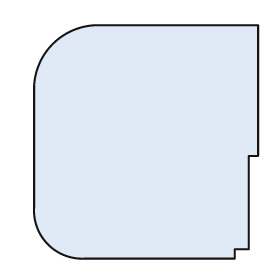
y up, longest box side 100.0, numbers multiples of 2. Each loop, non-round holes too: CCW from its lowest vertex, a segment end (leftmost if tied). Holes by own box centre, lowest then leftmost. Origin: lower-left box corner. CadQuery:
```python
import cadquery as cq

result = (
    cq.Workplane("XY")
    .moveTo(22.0, 0.0)
    .lineTo(86.0, 0.0)
    .lineTo(86.0, 4.0)
    .lineTo(92.0, 4.0)
    .lineTo(92.0, 44.0)
    .lineTo(96.0, 44.0)
    .lineTo(96.0, 100.0)
    .lineTo(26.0, 100.0)
    .threePointArc((8.0, 92.0), (0.0, 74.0))
    .lineTo(0.0, 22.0)
    .threePointArc((6.0, 6.0), (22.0, 0.0))
    .close()
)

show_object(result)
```